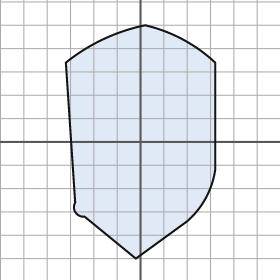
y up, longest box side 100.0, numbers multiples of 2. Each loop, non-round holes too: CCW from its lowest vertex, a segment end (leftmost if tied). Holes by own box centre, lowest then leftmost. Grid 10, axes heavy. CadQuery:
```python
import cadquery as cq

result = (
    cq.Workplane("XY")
    .moveTo(-2.0, -50.0)
    .lineTo(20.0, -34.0)
    .threePointArc((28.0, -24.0), (32.0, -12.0))
    .lineTo(32.0, 34.0)
    .threePointArc((18.0, 44.0), (2.0, 50.0))
    .threePointArc((-16.0, 44.0), (-32.0, 34.0))
    .lineTo(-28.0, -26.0)
    .threePointArc((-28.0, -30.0), (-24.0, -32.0))
    .close()
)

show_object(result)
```